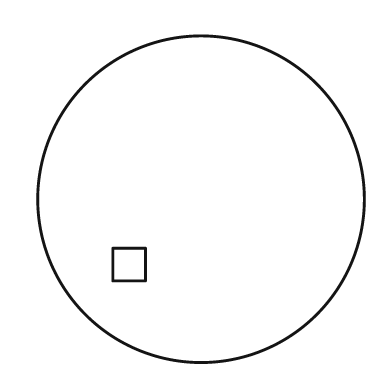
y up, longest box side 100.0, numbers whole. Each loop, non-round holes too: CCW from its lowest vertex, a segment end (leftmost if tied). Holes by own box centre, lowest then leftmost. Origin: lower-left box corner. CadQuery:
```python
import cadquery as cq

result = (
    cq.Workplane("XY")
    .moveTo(50.0, 50.0)
    .circle(50.0)
    .moveTo(23.0, 25.0)
    .lineTo(33.0, 25.0)
    .lineTo(33.0, 35.0)
    .lineTo(23.0, 35.0)
    .close()
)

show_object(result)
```